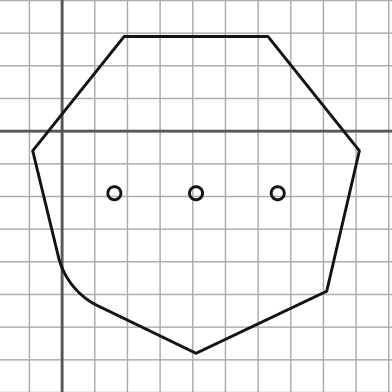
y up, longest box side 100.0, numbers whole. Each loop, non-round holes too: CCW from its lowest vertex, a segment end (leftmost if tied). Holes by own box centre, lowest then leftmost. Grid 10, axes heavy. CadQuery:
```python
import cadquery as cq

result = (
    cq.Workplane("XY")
    .moveTo(41.0, -68.0)
    .lineTo(81.0, -49.0)
    .lineTo(91.0, -6.0)
    .lineTo(63.0, 29.0)
    .lineTo(19.0, 29.0)
    .lineTo(-9.0, -6.0)
    .lineTo(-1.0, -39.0)
    .threePointArc((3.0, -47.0), (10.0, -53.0))
    .close()
    .moveTo(16.0, -19.0)
    .circle(2.0)
    .moveTo(41.0, -19.0)
    .circle(2.0)
    .moveTo(66.0, -19.0)
    .circle(2.0)
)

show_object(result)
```